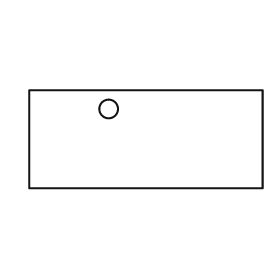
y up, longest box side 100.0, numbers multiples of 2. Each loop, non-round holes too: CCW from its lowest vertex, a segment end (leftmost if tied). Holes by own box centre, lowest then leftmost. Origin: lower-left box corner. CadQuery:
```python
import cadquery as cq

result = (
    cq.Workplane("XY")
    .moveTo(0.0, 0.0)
    .lineTo(100.0, 0.0)
    .lineTo(100.0, 42.0)
    .lineTo(0.0, 42.0)
    .close()
    .moveTo(34.0, 34.0)
    .circle(4.0)
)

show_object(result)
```